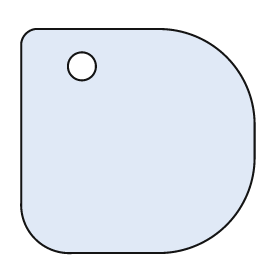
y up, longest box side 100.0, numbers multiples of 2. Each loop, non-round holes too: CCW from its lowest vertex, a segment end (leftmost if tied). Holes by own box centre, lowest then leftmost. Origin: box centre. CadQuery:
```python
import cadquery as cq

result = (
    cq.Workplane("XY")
    .moveTo(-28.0, -48.0)
    .lineTo(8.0, -48.0)
    .threePointArc((38.0, -36.0), (50.0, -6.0))
    .lineTo(50.0, 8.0)
    .threePointArc((38.0, 36.0), (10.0, 48.0))
    .lineTo(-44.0, 48.0)
    .threePointArc((-48.0, 46.0), (-50.0, 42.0))
    .lineTo(-50.0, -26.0)
    .threePointArc((-44.0, -42.0), (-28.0, -48.0))
    .close()
    .moveTo(-24.0, 32.0)
    .circle(6.0)
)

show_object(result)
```